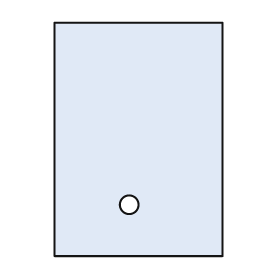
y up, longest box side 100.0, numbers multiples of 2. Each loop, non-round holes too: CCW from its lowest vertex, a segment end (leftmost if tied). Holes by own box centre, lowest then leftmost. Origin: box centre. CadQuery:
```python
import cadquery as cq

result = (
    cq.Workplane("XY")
    .moveTo(-36.0, -50.0)
    .lineTo(36.0, -50.0)
    .lineTo(36.0, 50.0)
    .lineTo(-36.0, 50.0)
    .close()
    .moveTo(-4.0, -28.0)
    .circle(4.0)
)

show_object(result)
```